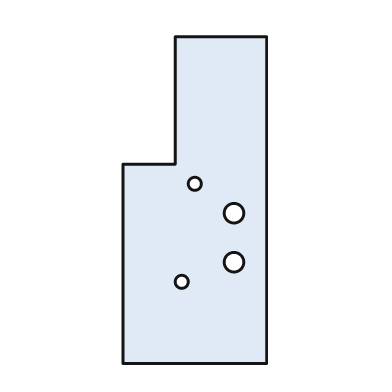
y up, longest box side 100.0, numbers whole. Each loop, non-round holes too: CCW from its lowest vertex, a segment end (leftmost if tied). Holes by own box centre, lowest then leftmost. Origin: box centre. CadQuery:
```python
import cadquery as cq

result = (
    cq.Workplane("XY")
    .moveTo(-22.0, -50.0)
    .lineTo(22.0, -50.0)
    .lineTo(22.0, 50.0)
    .lineTo(-6.0, 50.0)
    .lineTo(-6.0, 11.0)
    .lineTo(-22.0, 11.0)
    .close()
    .moveTo(-4.0, -25.0)
    .circle(2.0)
    .moveTo(12.0, -19.0)
    .circle(3.0)
    .moveTo(12.0, -4.0)
    .circle(3.0)
    .moveTo(0.0, 5.0)
    .circle(2.0)
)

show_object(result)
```